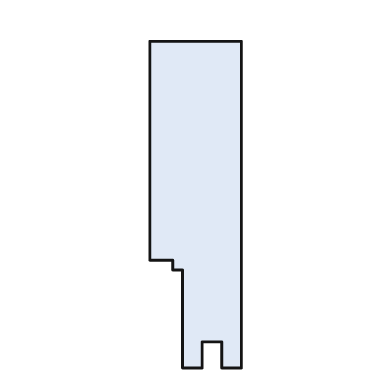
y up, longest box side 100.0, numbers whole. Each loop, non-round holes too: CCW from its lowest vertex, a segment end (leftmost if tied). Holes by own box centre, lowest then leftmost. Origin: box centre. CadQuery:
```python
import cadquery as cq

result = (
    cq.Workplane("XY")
    .moveTo(-4.0, -50.0)
    .lineTo(2.0, -50.0)
    .lineTo(2.0, -42.0)
    .lineTo(8.0, -42.0)
    .lineTo(8.0, -50.0)
    .lineTo(14.0, -50.0)
    .lineTo(14.0, 50.0)
    .lineTo(-14.0, 50.0)
    .lineTo(-14.0, -17.0)
    .lineTo(-7.0, -17.0)
    .lineTo(-7.0, -20.0)
    .lineTo(-4.0, -20.0)
    .close()
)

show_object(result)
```